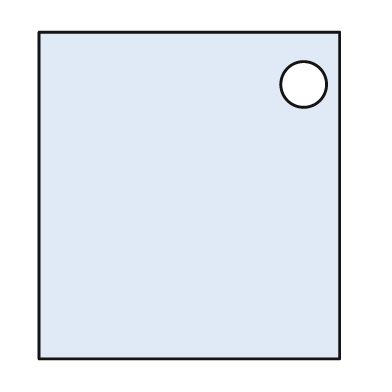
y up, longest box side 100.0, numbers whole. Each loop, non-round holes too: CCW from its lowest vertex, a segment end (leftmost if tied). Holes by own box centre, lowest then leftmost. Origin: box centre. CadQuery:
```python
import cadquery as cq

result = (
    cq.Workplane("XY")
    .moveTo(-46.0, -50.0)
    .lineTo(46.0, -50.0)
    .lineTo(46.0, 50.0)
    .lineTo(-46.0, 50.0)
    .close()
    .moveTo(35.0, 34.0)
    .circle(7.0)
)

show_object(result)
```